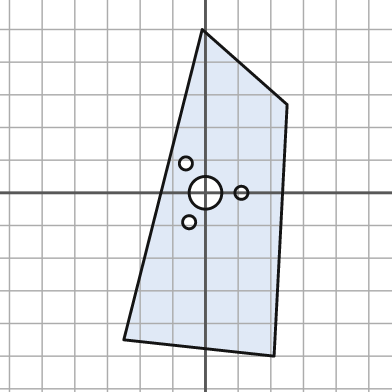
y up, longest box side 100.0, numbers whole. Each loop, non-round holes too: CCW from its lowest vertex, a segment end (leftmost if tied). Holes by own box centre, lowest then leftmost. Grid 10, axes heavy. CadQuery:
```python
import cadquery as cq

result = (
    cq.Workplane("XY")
    .moveTo(21.0, -50.0)
    .lineTo(25.0, 27.0)
    .lineTo(-1.0, 50.0)
    .lineTo(-25.0, -45.0)
    .close()
    .moveTo(-5.0, -9.0)
    .circle(2.0)
    .moveTo(0.0, 0.0)
    .circle(5.0)
    .moveTo(11.0, 0.0)
    .circle(2.0)
    .moveTo(-6.0, 9.0)
    .circle(2.0)
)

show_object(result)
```